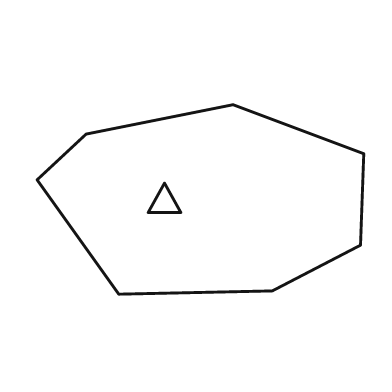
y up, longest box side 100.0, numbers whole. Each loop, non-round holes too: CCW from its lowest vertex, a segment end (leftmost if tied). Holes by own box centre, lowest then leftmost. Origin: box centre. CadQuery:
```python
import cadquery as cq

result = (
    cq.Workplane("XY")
    .moveTo(-25.0, -29.0)
    .lineTo(22.0, -28.0)
    .lineTo(49.0, -14.0)
    .lineTo(50.0, 14.0)
    .lineTo(10.0, 29.0)
    .lineTo(-35.0, 20.0)
    .lineTo(-50.0, 6.0)
    .close()
    .moveTo(-16.0, -4.0)
    .lineTo(-6.0, -4.0)
    .lineTo(-11.0, 5.0)
    .close()
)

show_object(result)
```